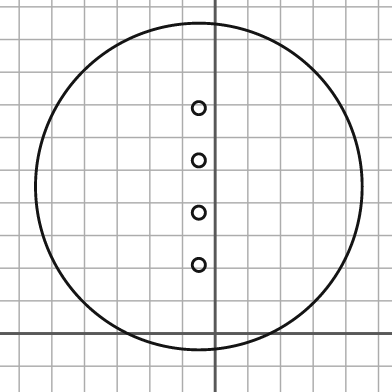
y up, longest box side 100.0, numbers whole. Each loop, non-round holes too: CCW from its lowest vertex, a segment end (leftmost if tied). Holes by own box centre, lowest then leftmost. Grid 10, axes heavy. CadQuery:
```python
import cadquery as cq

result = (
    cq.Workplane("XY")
    .moveTo(-5.0, 45.0)
    .circle(50.0)
    .moveTo(-5.0, 21.0)
    .circle(2.0)
    .moveTo(-5.0, 37.0)
    .circle(2.0)
    .moveTo(-5.0, 53.0)
    .circle(2.0)
    .moveTo(-5.0, 69.0)
    .circle(2.0)
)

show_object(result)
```